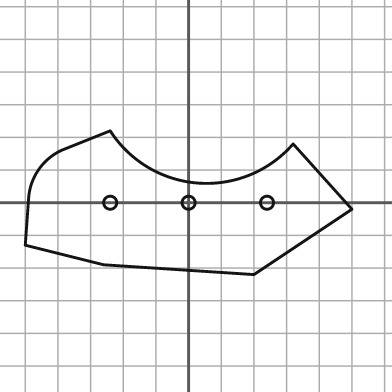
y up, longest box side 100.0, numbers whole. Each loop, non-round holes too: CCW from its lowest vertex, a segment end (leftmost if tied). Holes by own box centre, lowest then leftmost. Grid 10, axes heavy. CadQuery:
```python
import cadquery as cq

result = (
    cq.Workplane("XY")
    .moveTo(20.0, -22.0)
    .lineTo(50.0, -2.0)
    .lineTo(32.0, 18.0)
    .threePointArc((3.0, 6.0), (-24.0, 22.0))
    .lineTo(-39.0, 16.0)
    .threePointArc((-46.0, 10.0), (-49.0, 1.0))
    .lineTo(-50.0, -13.0)
    .lineTo(-26.0, -19.0)
    .close()
    .moveTo(-24.0, 0.0)
    .circle(2.0)
    .moveTo(0.0, 0.0)
    .circle(2.0)
    .moveTo(24.0, 0.0)
    .circle(2.0)
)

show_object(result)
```